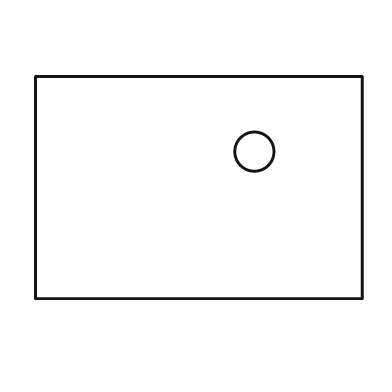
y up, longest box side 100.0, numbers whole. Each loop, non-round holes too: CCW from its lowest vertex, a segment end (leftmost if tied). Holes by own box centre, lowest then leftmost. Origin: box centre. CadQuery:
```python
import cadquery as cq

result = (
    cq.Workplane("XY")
    .moveTo(-50.0, -34.0)
    .lineTo(50.0, -34.0)
    .lineTo(50.0, 34.0)
    .lineTo(-50.0, 34.0)
    .close()
    .moveTo(17.0, 11.0)
    .circle(6.0)
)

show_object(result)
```